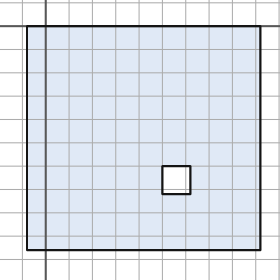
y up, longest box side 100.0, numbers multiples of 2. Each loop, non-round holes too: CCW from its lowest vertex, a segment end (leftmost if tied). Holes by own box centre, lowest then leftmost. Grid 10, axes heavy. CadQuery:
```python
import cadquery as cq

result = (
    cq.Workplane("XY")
    .moveTo(-8.0, -96.0)
    .lineTo(92.0, -96.0)
    .lineTo(92.0, 0.0)
    .lineTo(-8.0, 0.0)
    .close()
    .moveTo(50.0, -72.0)
    .lineTo(62.0, -72.0)
    .lineTo(62.0, -60.0)
    .lineTo(50.0, -60.0)
    .close()
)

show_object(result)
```